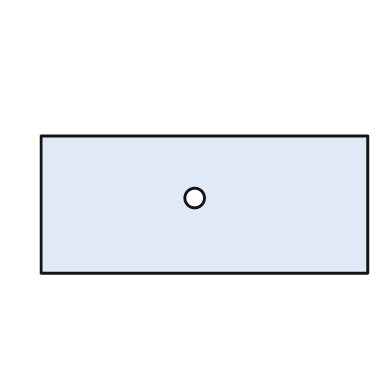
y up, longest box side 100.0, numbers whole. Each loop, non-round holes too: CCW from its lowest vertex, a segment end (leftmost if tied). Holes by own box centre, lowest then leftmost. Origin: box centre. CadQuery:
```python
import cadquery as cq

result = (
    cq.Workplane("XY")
    .moveTo(-50.0, -21.0)
    .lineTo(50.0, -21.0)
    .lineTo(50.0, 21.0)
    .lineTo(-50.0, 21.0)
    .close()
    .moveTo(-3.0, 2.0)
    .circle(3.0)
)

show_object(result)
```